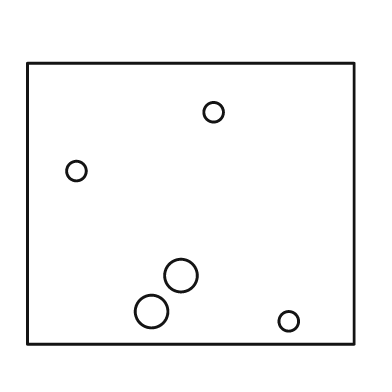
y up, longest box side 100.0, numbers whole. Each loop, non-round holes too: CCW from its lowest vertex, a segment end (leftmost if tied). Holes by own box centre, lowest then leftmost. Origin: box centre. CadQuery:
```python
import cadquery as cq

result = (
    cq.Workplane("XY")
    .moveTo(-50.0, -43.0)
    .lineTo(50.0, -43.0)
    .lineTo(50.0, 43.0)
    .lineTo(-50.0, 43.0)
    .close()
    .moveTo(30.0, -36.0)
    .circle(3.0)
    .moveTo(-12.0, -33.0)
    .circle(5.0)
    .moveTo(-3.0, -22.0)
    .circle(5.0)
    .moveTo(-35.0, 10.0)
    .circle(3.0)
    .moveTo(7.0, 28.0)
    .circle(3.0)
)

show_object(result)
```